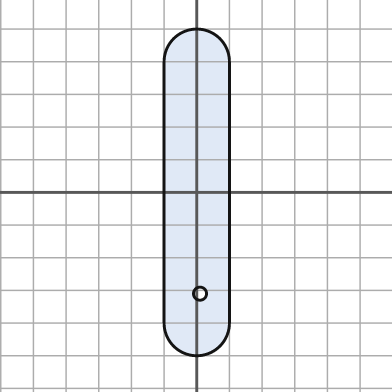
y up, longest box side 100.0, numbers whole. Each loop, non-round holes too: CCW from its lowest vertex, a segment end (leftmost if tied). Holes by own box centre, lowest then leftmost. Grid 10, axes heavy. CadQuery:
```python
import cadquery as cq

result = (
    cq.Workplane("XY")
    .moveTo(-10.0, -40.0)
    .threePointArc((0.0, -50.0), (10.0, -40.0))
    .lineTo(10.0, 40.0)
    .threePointArc((0.0, 50.0), (-10.0, 40.0))
    .close()
    .moveTo(1.0, -31.0)
    .circle(2.0)
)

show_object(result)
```